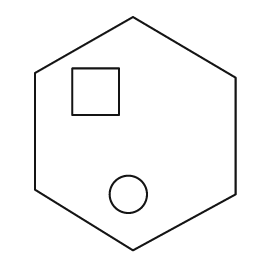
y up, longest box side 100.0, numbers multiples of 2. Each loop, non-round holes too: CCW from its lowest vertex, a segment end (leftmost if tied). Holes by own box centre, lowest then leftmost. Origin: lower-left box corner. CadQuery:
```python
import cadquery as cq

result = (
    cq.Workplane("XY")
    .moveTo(42.0, 0.0)
    .lineTo(86.0, 24.0)
    .lineTo(86.0, 74.0)
    .lineTo(42.0, 100.0)
    .lineTo(0.0, 76.0)
    .lineTo(0.0, 26.0)
    .close()
    .moveTo(40.0, 24.0)
    .circle(8.0)
    .moveTo(16.0, 58.0)
    .lineTo(36.0, 58.0)
    .lineTo(36.0, 78.0)
    .lineTo(16.0, 78.0)
    .close()
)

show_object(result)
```